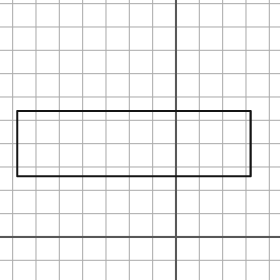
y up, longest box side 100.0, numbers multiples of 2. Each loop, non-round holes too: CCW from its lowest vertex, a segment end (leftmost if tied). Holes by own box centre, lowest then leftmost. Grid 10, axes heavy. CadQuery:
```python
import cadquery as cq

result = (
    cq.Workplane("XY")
    .moveTo(-68.0, 26.0)
    .lineTo(32.0, 26.0)
    .lineTo(32.0, 54.0)
    .lineTo(-68.0, 54.0)
    .close()
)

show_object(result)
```